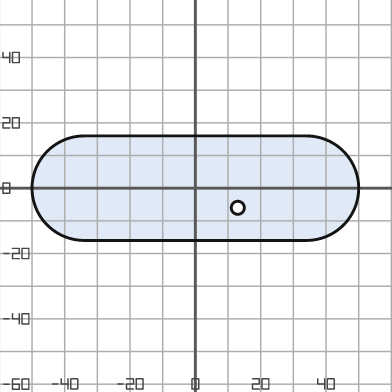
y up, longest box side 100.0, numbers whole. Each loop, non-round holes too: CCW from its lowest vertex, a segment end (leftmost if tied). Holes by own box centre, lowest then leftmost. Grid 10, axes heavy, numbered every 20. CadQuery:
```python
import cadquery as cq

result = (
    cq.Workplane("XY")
    .moveTo(-34.0, -16.0)
    .lineTo(34.0, -16.0)
    .threePointArc((50.0, 0.0), (34.0, 16.0))
    .lineTo(-34.0, 16.0)
    .threePointArc((-50.0, 0.0), (-34.0, -16.0))
    .close()
    .moveTo(13.0, -6.0)
    .circle(2.0)
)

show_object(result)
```